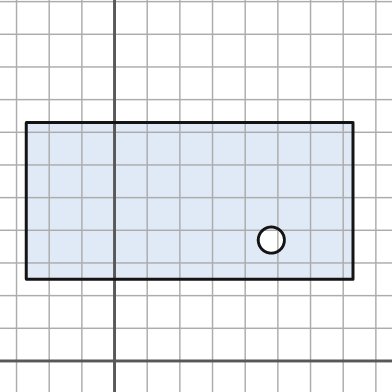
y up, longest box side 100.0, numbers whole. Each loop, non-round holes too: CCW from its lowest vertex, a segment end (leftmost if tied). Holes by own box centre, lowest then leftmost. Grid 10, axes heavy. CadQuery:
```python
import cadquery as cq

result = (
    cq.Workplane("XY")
    .moveTo(-27.0, 25.0)
    .lineTo(73.0, 25.0)
    .lineTo(73.0, 73.0)
    .lineTo(-27.0, 73.0)
    .close()
    .moveTo(48.0, 37.0)
    .circle(4.0)
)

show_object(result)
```